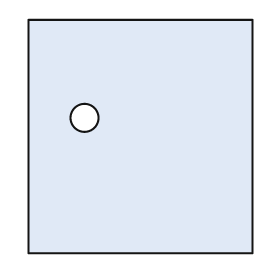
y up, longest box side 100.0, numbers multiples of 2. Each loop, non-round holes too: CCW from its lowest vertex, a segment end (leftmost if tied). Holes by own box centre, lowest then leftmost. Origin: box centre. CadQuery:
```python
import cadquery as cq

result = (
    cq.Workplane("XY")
    .moveTo(-48.0, -50.0)
    .lineTo(48.0, -50.0)
    .lineTo(48.0, 50.0)
    .lineTo(-48.0, 50.0)
    .close()
    .moveTo(-24.0, 8.0)
    .circle(6.0)
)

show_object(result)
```